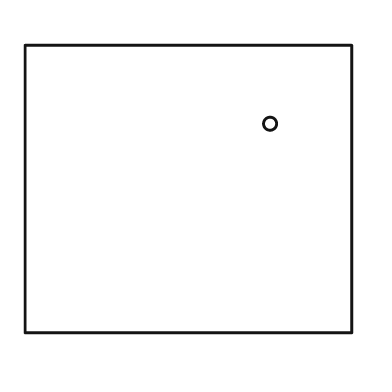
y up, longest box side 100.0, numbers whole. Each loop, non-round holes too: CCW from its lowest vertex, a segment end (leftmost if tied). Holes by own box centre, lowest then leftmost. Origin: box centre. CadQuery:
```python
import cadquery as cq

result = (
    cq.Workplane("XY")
    .moveTo(-50.0, -44.0)
    .lineTo(50.0, -44.0)
    .lineTo(50.0, 44.0)
    .lineTo(-50.0, 44.0)
    .close()
    .moveTo(25.0, 20.0)
    .circle(2.0)
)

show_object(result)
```